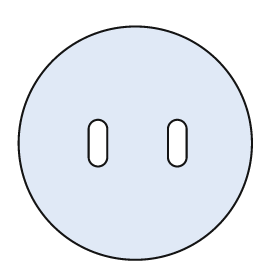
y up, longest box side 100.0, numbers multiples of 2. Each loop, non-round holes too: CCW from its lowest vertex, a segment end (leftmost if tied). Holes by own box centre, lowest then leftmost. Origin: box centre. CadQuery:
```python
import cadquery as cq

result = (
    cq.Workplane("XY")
    .moveTo(0.0, 0.0)
    .circle(50.0)
    .moveTo(-20.0, -6.0)
    .threePointArc((-16.0, -10.0), (-12.0, -6.0))
    .lineTo(-12.0, 6.0)
    .threePointArc((-16.0, 10.0), (-20.0, 6.0))
    .close()
    .moveTo(14.0, -6.0)
    .threePointArc((18.0, -10.0), (22.0, -6.0))
    .lineTo(22.0, 6.0)
    .threePointArc((18.0, 10.0), (14.0, 6.0))
    .close()
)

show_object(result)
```